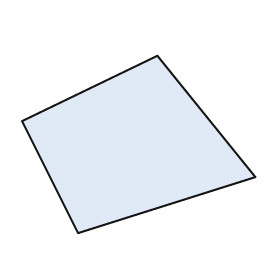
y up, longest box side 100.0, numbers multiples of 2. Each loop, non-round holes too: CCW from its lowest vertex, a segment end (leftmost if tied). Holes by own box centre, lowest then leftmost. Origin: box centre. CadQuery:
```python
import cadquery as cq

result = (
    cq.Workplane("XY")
    .moveTo(-26.0, -38.0)
    .lineTo(50.0, -14.0)
    .lineTo(8.0, 38.0)
    .lineTo(-50.0, 10.0)
    .close()
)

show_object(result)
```